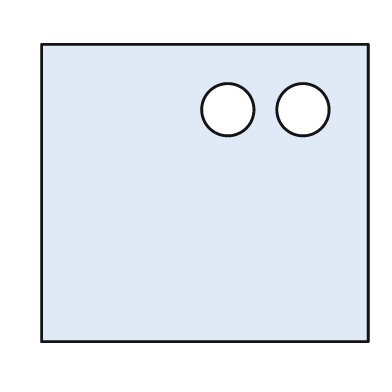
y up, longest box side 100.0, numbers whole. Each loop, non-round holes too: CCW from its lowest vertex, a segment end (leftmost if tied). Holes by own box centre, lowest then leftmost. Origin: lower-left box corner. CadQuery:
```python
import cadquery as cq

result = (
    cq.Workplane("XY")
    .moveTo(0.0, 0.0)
    .lineTo(100.0, 0.0)
    .lineTo(100.0, 91.0)
    .lineTo(0.0, 91.0)
    .close()
    .moveTo(57.0, 71.0)
    .circle(8.0)
    .moveTo(80.0, 71.0)
    .circle(8.0)
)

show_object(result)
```